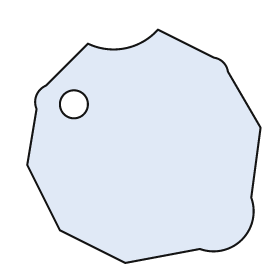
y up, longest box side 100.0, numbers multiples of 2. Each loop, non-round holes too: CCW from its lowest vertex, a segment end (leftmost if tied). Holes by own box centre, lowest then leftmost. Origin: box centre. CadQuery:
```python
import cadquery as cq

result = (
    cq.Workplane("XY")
    .moveTo(-8.0, -50.0)
    .lineTo(24.0, -44.0)
    .threePointArc((42.0, -40.0), (46.0, -22.0))
    .lineTo(50.0, 8.0)
    .lineTo(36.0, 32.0)
    .threePointArc((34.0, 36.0), (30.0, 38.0))
    .lineTo(6.0, 50.0)
    .threePointArc((-8.0, 42.0), (-24.0, 44.0))
    .lineTo(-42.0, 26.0)
    .threePointArc((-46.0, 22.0), (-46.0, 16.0))
    .lineTo(-50.0, -8.0)
    .lineTo(-36.0, -36.0)
    .close()
    .moveTo(-30.0, 18.0)
    .circle(6.0)
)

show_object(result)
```